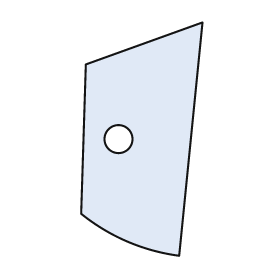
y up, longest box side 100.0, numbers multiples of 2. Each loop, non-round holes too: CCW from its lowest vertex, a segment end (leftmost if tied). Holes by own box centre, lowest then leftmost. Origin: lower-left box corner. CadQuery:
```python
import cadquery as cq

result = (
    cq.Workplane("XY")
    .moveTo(42.0, 0.0)
    .lineTo(52.0, 100.0)
    .lineTo(2.0, 82.0)
    .lineTo(0.0, 18.0)
    .threePointArc((20.0, 6.0), (42.0, 0.0))
    .close()
    .moveTo(16.0, 50.0)
    .circle(6.0)
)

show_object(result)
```